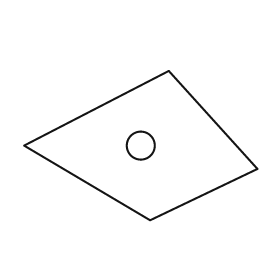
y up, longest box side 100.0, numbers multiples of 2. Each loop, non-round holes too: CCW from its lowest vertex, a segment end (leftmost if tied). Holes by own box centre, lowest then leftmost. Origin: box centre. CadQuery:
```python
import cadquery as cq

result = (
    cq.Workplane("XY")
    .moveTo(4.0, -32.0)
    .lineTo(50.0, -10.0)
    .lineTo(12.0, 32.0)
    .lineTo(-50.0, 0.0)
    .close()
    .moveTo(0.0, 0.0)
    .circle(6.0)
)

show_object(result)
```